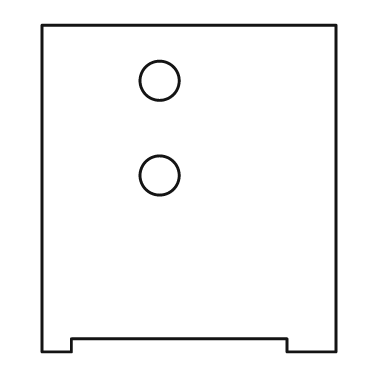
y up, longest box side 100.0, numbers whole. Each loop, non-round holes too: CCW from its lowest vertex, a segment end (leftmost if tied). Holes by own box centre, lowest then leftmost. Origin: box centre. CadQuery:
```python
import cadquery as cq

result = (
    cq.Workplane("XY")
    .moveTo(-45.0, -50.0)
    .lineTo(-36.0, -50.0)
    .lineTo(-36.0, -46.0)
    .lineTo(30.0, -46.0)
    .lineTo(30.0, -50.0)
    .lineTo(45.0, -50.0)
    .lineTo(45.0, 50.0)
    .lineTo(-45.0, 50.0)
    .close()
    .moveTo(-9.0, 4.0)
    .circle(6.0)
    .moveTo(-9.0, 33.0)
    .circle(6.0)
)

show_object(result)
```